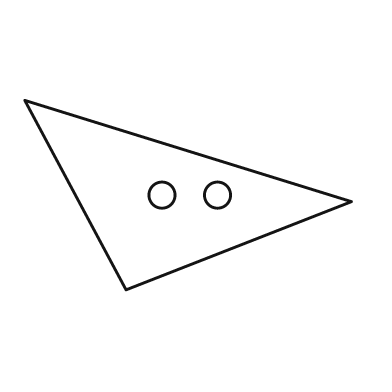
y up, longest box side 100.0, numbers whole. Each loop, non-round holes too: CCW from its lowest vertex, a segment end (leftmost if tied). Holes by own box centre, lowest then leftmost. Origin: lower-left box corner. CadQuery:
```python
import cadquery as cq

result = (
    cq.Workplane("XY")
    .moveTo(31.0, 0.0)
    .lineTo(100.0, 27.0)
    .lineTo(0.0, 58.0)
    .close()
    .moveTo(42.0, 29.0)
    .circle(4.0)
    .moveTo(59.0, 29.0)
    .circle(4.0)
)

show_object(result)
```